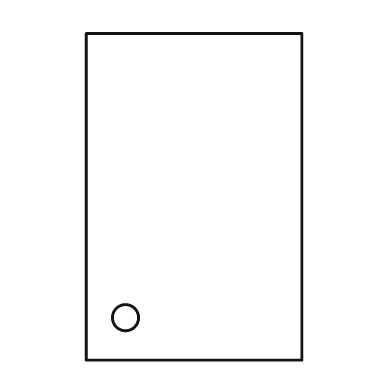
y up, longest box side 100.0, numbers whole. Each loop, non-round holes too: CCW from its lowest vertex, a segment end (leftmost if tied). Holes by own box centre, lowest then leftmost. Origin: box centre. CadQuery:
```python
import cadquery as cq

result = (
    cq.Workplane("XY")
    .moveTo(-33.0, -50.0)
    .lineTo(33.0, -50.0)
    .lineTo(33.0, 50.0)
    .lineTo(-33.0, 50.0)
    .close()
    .moveTo(-21.0, -37.0)
    .circle(4.0)
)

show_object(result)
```